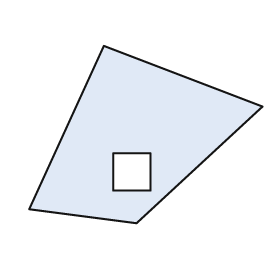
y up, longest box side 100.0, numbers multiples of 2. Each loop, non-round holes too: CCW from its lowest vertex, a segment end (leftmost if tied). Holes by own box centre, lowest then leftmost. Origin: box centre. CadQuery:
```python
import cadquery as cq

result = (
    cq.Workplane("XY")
    .moveTo(-4.0, -38.0)
    .lineTo(50.0, 12.0)
    .lineTo(-18.0, 38.0)
    .lineTo(-50.0, -32.0)
    .close()
    .moveTo(-14.0, -24.0)
    .lineTo(2.0, -24.0)
    .lineTo(2.0, -8.0)
    .lineTo(-14.0, -8.0)
    .close()
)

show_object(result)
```